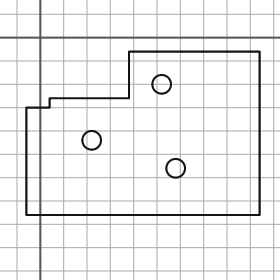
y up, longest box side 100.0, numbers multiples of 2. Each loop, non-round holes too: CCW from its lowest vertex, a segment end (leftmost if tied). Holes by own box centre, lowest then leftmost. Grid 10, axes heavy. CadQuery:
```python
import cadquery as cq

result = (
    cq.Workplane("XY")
    .moveTo(-6.0, -76.0)
    .lineTo(94.0, -76.0)
    .lineTo(94.0, -6.0)
    .lineTo(38.0, -6.0)
    .lineTo(38.0, -26.0)
    .lineTo(4.0, -26.0)
    .lineTo(4.0, -30.0)
    .lineTo(-6.0, -30.0)
    .close()
    .moveTo(58.0, -56.0)
    .circle(4.0)
    .moveTo(22.0, -44.0)
    .circle(4.0)
    .moveTo(52.0, -20.0)
    .circle(4.0)
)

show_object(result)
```